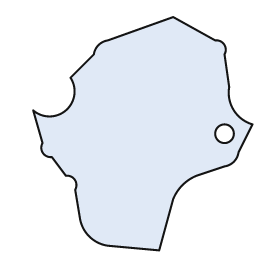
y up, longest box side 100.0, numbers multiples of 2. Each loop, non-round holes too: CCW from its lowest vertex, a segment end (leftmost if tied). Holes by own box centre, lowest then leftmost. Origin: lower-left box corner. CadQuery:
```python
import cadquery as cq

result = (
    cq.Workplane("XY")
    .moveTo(54.0, 0.0)
    .lineTo(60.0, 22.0)
    .threePointArc((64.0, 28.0), (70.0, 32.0))
    .lineTo(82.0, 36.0)
    .threePointArc((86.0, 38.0), (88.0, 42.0))
    .lineTo(94.0, 54.0)
    .threePointArc((86.0, 60.0), (84.0, 70.0))
    .lineTo(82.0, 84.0)
    .threePointArc((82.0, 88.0), (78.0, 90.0))
    .lineTo(60.0, 100.0)
    .lineTo(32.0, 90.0)
    .threePointArc((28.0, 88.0), (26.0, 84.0))
    .lineTo(16.0, 74.0)
    .threePointArc((14.0, 60.0), (0.0, 60.0))
    .lineTo(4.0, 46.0)
    .threePointArc((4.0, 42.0), (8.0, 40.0))
    .lineTo(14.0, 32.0)
    .threePointArc((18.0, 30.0), (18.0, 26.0))
    .lineTo(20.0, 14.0)
    .threePointArc((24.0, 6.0), (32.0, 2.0))
    .close()
    .moveTo(82.0, 50.0)
    .circle(4.0)
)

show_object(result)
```